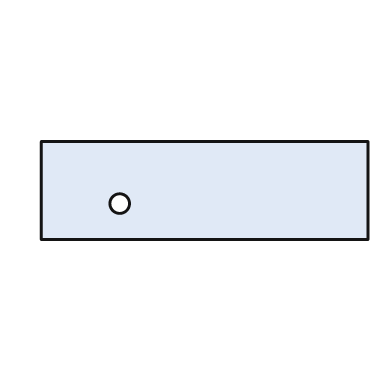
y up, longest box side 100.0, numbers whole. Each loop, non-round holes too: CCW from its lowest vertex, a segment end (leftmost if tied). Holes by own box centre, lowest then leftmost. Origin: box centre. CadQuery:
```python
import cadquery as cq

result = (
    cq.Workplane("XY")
    .moveTo(-50.0, -15.0)
    .lineTo(50.0, -15.0)
    .lineTo(50.0, 15.0)
    .lineTo(-50.0, 15.0)
    .close()
    .moveTo(-26.0, -4.0)
    .circle(3.0)
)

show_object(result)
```